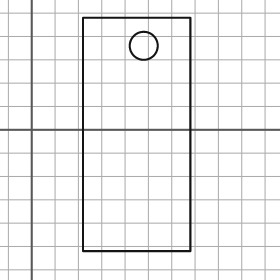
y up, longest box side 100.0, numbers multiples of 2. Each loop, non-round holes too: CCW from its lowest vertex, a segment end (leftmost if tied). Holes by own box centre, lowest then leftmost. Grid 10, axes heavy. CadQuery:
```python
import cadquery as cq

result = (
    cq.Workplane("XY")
    .moveTo(22.0, -52.0)
    .lineTo(68.0, -52.0)
    .lineTo(68.0, 48.0)
    .lineTo(22.0, 48.0)
    .close()
    .moveTo(48.0, 36.0)
    .circle(6.0)
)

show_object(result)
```